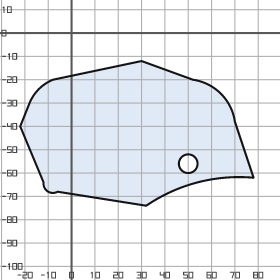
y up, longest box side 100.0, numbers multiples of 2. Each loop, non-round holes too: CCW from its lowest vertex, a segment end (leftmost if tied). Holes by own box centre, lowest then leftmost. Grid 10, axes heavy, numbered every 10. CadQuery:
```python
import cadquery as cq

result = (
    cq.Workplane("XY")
    .moveTo(32.0, -74.0)
    .threePointArc((54.0, -64.0), (78.0, -62.0))
    .lineTo(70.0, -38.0)
    .threePointArc((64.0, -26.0), (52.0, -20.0))
    .lineTo(30.0, -12.0)
    .lineTo(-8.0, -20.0)
    .threePointArc((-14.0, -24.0), (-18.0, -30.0))
    .lineTo(-22.0, -40.0)
    .lineTo(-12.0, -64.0)
    .threePointArc((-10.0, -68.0), (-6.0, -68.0))
    .close()
    .moveTo(50.0, -56.0)
    .circle(4.0)
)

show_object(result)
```